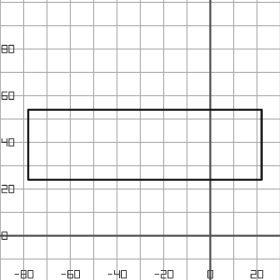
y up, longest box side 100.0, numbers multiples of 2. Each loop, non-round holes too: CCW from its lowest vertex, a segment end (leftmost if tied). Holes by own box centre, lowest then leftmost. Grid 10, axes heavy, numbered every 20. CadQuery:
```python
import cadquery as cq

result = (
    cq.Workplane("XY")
    .moveTo(-78.0, 24.0)
    .lineTo(22.0, 24.0)
    .lineTo(22.0, 54.0)
    .lineTo(-78.0, 54.0)
    .close()
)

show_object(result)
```